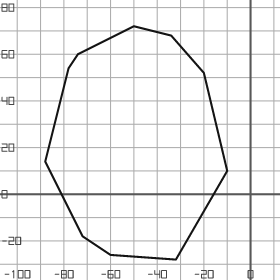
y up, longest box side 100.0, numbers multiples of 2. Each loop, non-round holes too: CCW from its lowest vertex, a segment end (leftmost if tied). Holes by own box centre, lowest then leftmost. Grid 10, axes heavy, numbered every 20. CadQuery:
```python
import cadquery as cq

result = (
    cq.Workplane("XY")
    .moveTo(-32.0, -28.0)
    .lineTo(-10.0, 10.0)
    .lineTo(-20.0, 52.0)
    .lineTo(-34.0, 68.0)
    .lineTo(-50.0, 72.0)
    .lineTo(-74.0, 60.0)
    .lineTo(-78.0, 54.0)
    .lineTo(-88.0, 14.0)
    .lineTo(-72.0, -18.0)
    .lineTo(-60.0, -26.0)
    .close()
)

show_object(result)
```